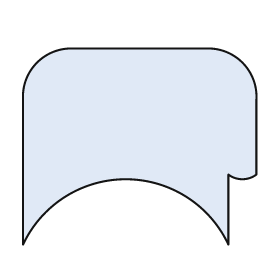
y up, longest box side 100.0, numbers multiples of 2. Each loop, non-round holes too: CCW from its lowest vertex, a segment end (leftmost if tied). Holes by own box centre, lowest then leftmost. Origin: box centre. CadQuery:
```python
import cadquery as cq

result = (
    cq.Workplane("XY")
    .moveTo(-50.0, -42.0)
    .threePointArc((-6.0, -14.0), (38.0, -42.0))
    .lineTo(38.0, -12.0)
    .threePointArc((44.0, -14.0), (50.0, -12.0))
    .lineTo(50.0, 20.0)
    .threePointArc((44.0, 36.0), (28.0, 42.0))
    .lineTo(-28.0, 42.0)
    .threePointArc((-44.0, 36.0), (-50.0, 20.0))
    .close()
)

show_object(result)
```